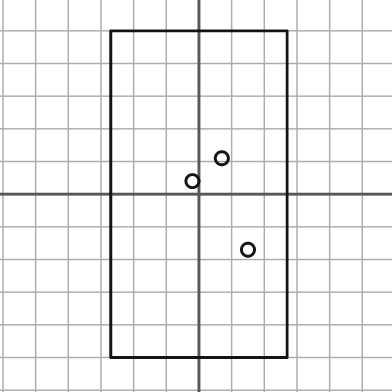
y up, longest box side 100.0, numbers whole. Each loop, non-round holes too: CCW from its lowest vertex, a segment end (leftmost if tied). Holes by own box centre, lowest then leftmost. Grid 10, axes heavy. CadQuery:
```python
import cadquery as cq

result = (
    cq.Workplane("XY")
    .moveTo(-27.0, -50.0)
    .lineTo(27.0, -50.0)
    .lineTo(27.0, 50.0)
    .lineTo(-27.0, 50.0)
    .close()
    .moveTo(15.0, -17.0)
    .circle(2.0)
    .moveTo(-2.0, 4.0)
    .circle(2.0)
    .moveTo(7.0, 11.0)
    .circle(2.0)
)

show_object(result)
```